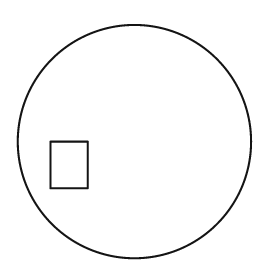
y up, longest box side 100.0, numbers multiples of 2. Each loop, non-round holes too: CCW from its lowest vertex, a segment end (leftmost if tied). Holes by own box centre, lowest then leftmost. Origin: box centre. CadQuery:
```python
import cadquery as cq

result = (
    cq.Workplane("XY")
    .moveTo(0.0, 0.0)
    .circle(50.0)
    .moveTo(-36.0, -20.0)
    .lineTo(-20.0, -20.0)
    .lineTo(-20.0, 0.0)
    .lineTo(-36.0, 0.0)
    .close()
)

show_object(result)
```